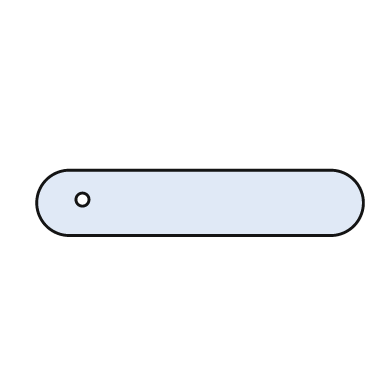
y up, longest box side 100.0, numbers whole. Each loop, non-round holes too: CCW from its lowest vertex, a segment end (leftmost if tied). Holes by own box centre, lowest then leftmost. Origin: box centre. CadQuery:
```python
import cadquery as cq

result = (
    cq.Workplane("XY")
    .moveTo(-40.0, -10.0)
    .lineTo(40.0, -10.0)
    .threePointArc((50.0, 0.0), (40.0, 10.0))
    .lineTo(-40.0, 10.0)
    .threePointArc((-50.0, 0.0), (-40.0, -10.0))
    .close()
    .moveTo(-36.0, 1.0)
    .circle(2.0)
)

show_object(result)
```